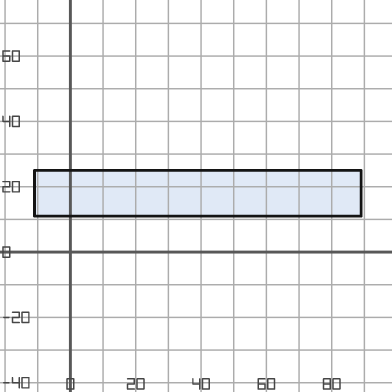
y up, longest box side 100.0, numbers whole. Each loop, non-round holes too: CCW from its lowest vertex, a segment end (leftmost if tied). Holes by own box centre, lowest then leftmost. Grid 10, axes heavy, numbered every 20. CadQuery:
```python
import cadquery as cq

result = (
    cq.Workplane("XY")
    .moveTo(-11.0, 11.0)
    .lineTo(89.0, 11.0)
    .lineTo(89.0, 25.0)
    .lineTo(-11.0, 25.0)
    .close()
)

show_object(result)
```